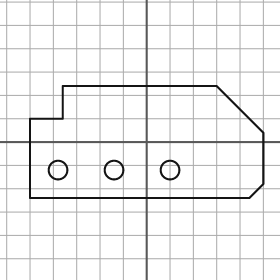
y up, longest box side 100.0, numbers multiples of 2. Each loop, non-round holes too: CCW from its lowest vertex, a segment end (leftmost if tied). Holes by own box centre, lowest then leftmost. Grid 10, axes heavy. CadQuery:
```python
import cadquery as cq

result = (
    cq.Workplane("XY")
    .moveTo(-50.0, -24.0)
    .lineTo(44.0, -24.0)
    .lineTo(50.0, -18.0)
    .lineTo(50.0, 4.0)
    .lineTo(30.0, 24.0)
    .lineTo(-36.0, 24.0)
    .lineTo(-36.0, 10.0)
    .lineTo(-50.0, 10.0)
    .close()
    .moveTo(-38.0, -12.0)
    .circle(4.0)
    .moveTo(-14.0, -12.0)
    .circle(4.0)
    .moveTo(10.0, -12.0)
    .circle(4.0)
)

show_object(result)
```